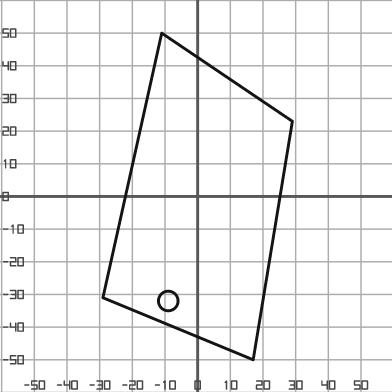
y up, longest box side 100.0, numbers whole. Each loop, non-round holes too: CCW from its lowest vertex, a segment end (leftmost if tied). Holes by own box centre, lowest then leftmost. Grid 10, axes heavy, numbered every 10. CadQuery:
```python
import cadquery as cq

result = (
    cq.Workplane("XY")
    .moveTo(17.0, -50.0)
    .lineTo(29.0, 23.0)
    .lineTo(-11.0, 50.0)
    .lineTo(-29.0, -31.0)
    .close()
    .moveTo(-9.0, -32.0)
    .circle(3.0)
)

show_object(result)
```